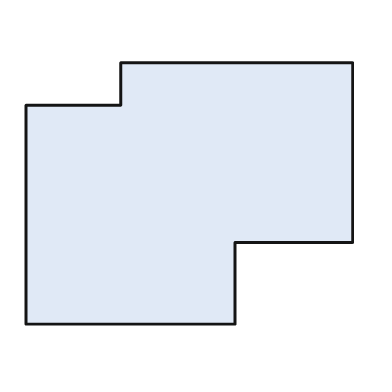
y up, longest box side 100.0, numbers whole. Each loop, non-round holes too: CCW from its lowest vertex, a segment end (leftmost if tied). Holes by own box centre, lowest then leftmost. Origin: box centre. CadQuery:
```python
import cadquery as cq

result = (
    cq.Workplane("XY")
    .moveTo(-50.0, -40.0)
    .lineTo(14.0, -40.0)
    .lineTo(14.0, -15.0)
    .lineTo(50.0, -15.0)
    .lineTo(50.0, 40.0)
    .lineTo(-21.0, 40.0)
    .lineTo(-21.0, 27.0)
    .lineTo(-50.0, 27.0)
    .close()
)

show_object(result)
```